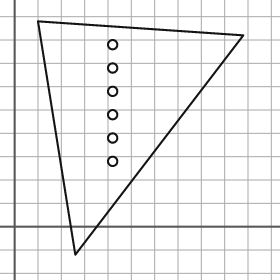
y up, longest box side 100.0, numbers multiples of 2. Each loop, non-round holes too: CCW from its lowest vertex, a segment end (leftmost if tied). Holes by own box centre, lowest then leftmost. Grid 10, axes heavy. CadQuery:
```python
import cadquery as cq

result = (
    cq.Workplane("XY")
    .moveTo(26.0, -12.0)
    .lineTo(98.0, 82.0)
    .lineTo(10.0, 88.0)
    .close()
    .moveTo(42.0, 28.0)
    .circle(2.0)
    .moveTo(42.0, 38.0)
    .circle(2.0)
    .moveTo(42.0, 48.0)
    .circle(2.0)
    .moveTo(42.0, 58.0)
    .circle(2.0)
    .moveTo(42.0, 68.0)
    .circle(2.0)
    .moveTo(42.0, 78.0)
    .circle(2.0)
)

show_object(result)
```